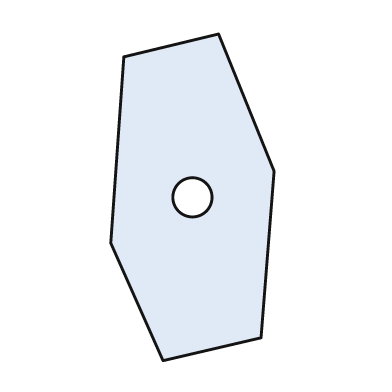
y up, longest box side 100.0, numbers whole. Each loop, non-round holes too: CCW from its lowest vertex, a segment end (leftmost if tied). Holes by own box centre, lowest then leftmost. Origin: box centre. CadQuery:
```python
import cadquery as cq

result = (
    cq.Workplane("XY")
    .moveTo(-9.0, -50.0)
    .lineTo(21.0, -43.0)
    .lineTo(25.0, 8.0)
    .lineTo(8.0, 50.0)
    .lineTo(-21.0, 43.0)
    .lineTo(-25.0, -14.0)
    .close()
    .moveTo(0.0, 0.0)
    .circle(6.0)
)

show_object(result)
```